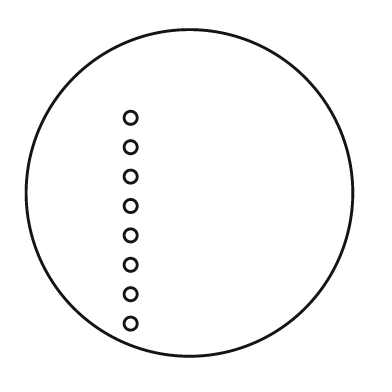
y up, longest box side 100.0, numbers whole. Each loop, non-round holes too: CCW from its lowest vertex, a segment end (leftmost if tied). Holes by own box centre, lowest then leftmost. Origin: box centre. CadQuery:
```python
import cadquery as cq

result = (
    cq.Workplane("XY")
    .moveTo(0.0, 0.0)
    .circle(50.0)
    .moveTo(-18.0, -40.0)
    .circle(2.0)
    .moveTo(-18.0, -31.0)
    .circle(2.0)
    .moveTo(-18.0, -22.0)
    .circle(2.0)
    .moveTo(-18.0, -13.0)
    .circle(2.0)
    .moveTo(-18.0, -4.0)
    .circle(2.0)
    .moveTo(-18.0, 5.0)
    .circle(2.0)
    .moveTo(-18.0, 14.0)
    .circle(2.0)
    .moveTo(-18.0, 23.0)
    .circle(2.0)
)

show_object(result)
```